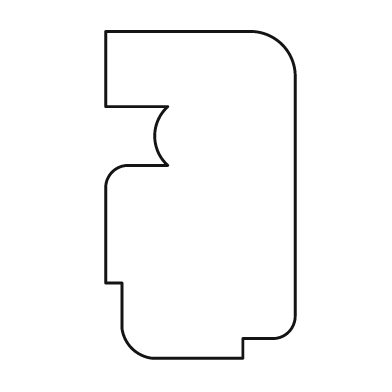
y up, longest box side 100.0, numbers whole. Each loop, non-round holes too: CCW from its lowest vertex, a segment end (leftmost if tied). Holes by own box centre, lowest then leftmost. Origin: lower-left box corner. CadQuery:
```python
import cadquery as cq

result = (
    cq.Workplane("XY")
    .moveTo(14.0, 0.0)
    .lineTo(42.0, 0.0)
    .lineTo(42.0, 6.0)
    .lineTo(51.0, 6.0)
    .threePointArc((56.0, 8.0), (58.0, 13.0))
    .lineTo(58.0, 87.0)
    .threePointArc((54.0, 96.0), (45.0, 100.0))
    .lineTo(0.0, 100.0)
    .lineTo(0.0, 77.0)
    .lineTo(19.0, 77.0)
    .threePointArc((15.0, 68.0), (19.0, 59.0))
    .lineTo(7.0, 59.0)
    .threePointArc((2.0, 57.0), (0.0, 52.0))
    .lineTo(0.0, 23.0)
    .lineTo(5.0, 23.0)
    .lineTo(5.0, 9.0)
    .threePointArc((8.0, 3.0), (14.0, 0.0))
    .close()
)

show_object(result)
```